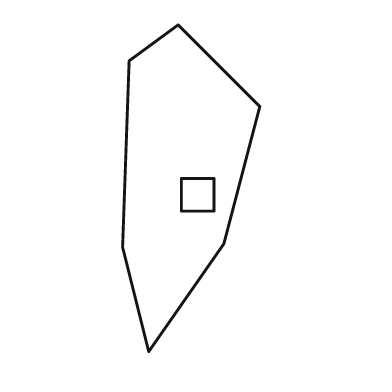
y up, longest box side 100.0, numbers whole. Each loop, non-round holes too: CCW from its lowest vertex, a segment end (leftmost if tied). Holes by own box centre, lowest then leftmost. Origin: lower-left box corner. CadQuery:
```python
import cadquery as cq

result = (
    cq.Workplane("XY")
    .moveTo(8.0, 0.0)
    .lineTo(31.0, 33.0)
    .lineTo(42.0, 75.0)
    .lineTo(17.0, 100.0)
    .lineTo(2.0, 89.0)
    .lineTo(0.0, 32.0)
    .close()
    .moveTo(18.0, 43.0)
    .lineTo(28.0, 43.0)
    .lineTo(28.0, 53.0)
    .lineTo(18.0, 53.0)
    .close()
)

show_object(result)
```